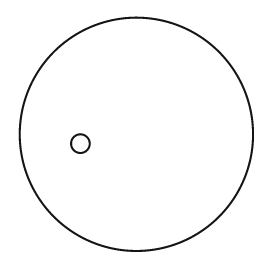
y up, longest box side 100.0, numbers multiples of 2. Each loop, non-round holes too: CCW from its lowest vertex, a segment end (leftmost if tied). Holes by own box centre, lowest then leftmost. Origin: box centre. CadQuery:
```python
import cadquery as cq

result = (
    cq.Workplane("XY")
    .moveTo(0.0, 0.0)
    .circle(50.0)
    .moveTo(-24.0, -4.0)
    .circle(4.0)
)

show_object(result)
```